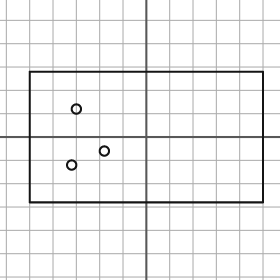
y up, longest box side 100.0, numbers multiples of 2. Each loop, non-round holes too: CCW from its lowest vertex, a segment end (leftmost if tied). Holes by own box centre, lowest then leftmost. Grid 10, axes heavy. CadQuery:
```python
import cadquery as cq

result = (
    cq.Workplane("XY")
    .moveTo(-50.0, -28.0)
    .lineTo(50.0, -28.0)
    .lineTo(50.0, 28.0)
    .lineTo(-50.0, 28.0)
    .close()
    .moveTo(-32.0, -12.0)
    .circle(2.0)
    .moveTo(-18.0, -6.0)
    .circle(2.0)
    .moveTo(-30.0, 12.0)
    .circle(2.0)
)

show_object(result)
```